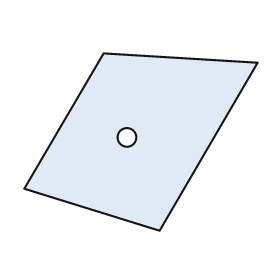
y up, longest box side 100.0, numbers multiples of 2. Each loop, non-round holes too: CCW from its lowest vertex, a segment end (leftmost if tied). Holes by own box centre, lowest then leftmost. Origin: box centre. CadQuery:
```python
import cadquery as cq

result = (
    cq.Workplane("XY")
    .moveTo(8.0, -38.0)
    .lineTo(50.0, 34.0)
    .lineTo(-16.0, 38.0)
    .lineTo(-50.0, -20.0)
    .close()
    .moveTo(-6.0, 2.0)
    .circle(4.0)
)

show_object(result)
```